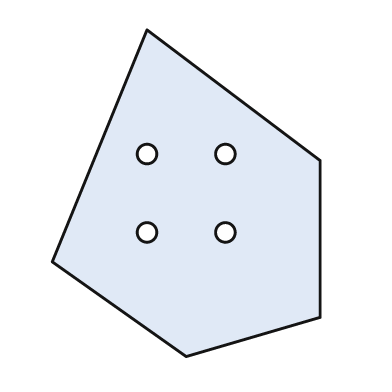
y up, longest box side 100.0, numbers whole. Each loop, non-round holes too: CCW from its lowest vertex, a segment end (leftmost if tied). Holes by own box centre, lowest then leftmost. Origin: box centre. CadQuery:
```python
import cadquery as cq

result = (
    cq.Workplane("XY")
    .moveTo(0.0, -50.0)
    .lineTo(41.0, -38.0)
    .lineTo(41.0, 10.0)
    .lineTo(-12.0, 50.0)
    .lineTo(-41.0, -21.0)
    .close()
    .moveTo(-12.0, -12.0)
    .circle(3.0)
    .moveTo(12.0, -12.0)
    .circle(3.0)
    .moveTo(-12.0, 12.0)
    .circle(3.0)
    .moveTo(12.0, 12.0)
    .circle(3.0)
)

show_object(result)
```